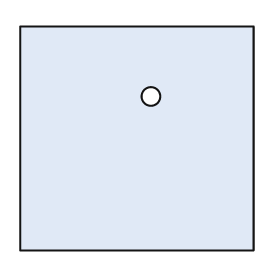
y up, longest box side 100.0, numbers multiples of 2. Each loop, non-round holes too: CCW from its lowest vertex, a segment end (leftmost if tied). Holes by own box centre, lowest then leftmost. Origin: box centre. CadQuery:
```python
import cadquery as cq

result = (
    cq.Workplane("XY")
    .moveTo(-50.0, -48.0)
    .lineTo(50.0, -48.0)
    .lineTo(50.0, 48.0)
    .lineTo(-50.0, 48.0)
    .close()
    .moveTo(6.0, 18.0)
    .circle(4.0)
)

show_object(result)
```